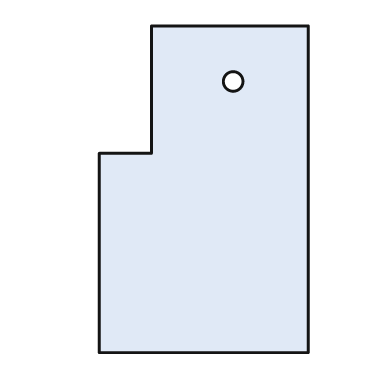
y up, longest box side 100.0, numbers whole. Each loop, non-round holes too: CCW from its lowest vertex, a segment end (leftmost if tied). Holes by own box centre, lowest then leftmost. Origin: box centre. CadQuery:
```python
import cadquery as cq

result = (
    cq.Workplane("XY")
    .moveTo(-32.0, -50.0)
    .lineTo(32.0, -50.0)
    .lineTo(32.0, 50.0)
    .lineTo(-16.0, 50.0)
    .lineTo(-16.0, 11.0)
    .lineTo(-32.0, 11.0)
    .close()
    .moveTo(9.0, 33.0)
    .circle(3.0)
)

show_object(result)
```